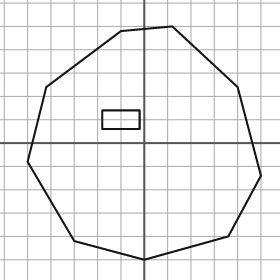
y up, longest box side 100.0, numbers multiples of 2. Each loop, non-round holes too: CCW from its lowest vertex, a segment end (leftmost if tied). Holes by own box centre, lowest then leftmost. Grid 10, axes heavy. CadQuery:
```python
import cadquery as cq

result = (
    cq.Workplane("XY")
    .moveTo(0.0, -50.0)
    .lineTo(36.0, -40.0)
    .lineTo(50.0, -14.0)
    .lineTo(40.0, 24.0)
    .lineTo(12.0, 50.0)
    .lineTo(-10.0, 48.0)
    .lineTo(-42.0, 24.0)
    .lineTo(-50.0, -8.0)
    .lineTo(-30.0, -42.0)
    .close()
    .moveTo(-18.0, 6.0)
    .lineTo(-2.0, 6.0)
    .lineTo(-2.0, 14.0)
    .lineTo(-18.0, 14.0)
    .close()
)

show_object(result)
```